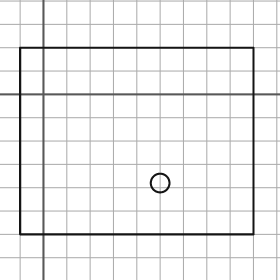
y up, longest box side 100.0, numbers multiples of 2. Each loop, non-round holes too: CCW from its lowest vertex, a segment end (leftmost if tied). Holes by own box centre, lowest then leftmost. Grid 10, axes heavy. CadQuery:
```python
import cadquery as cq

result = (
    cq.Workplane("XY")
    .moveTo(-10.0, -60.0)
    .lineTo(90.0, -60.0)
    .lineTo(90.0, 20.0)
    .lineTo(-10.0, 20.0)
    .close()
    .moveTo(50.0, -38.0)
    .circle(4.0)
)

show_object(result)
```